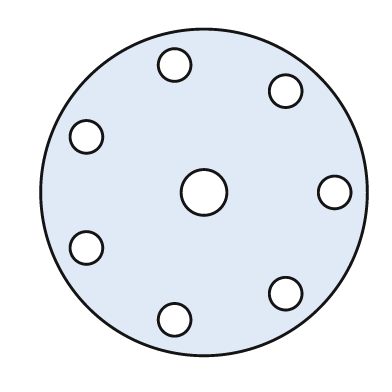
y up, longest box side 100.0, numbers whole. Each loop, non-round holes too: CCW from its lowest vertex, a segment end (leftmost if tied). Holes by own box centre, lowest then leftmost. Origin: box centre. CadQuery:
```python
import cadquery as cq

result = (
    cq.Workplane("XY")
    .moveTo(0.0, 0.0)
    .circle(50.0)
    .moveTo(-9.0, -39.0)
    .circle(5.0)
    .moveTo(25.0, -31.0)
    .circle(5.0)
    .moveTo(-36.0, -17.0)
    .circle(5.0)
    .moveTo(0.0, 0.0)
    .circle(7.0)
    .moveTo(40.0, 0.0)
    .circle(5.0)
    .moveTo(-36.0, 17.0)
    .circle(5.0)
    .moveTo(25.0, 31.0)
    .circle(5.0)
    .moveTo(-9.0, 39.0)
    .circle(5.0)
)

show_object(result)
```